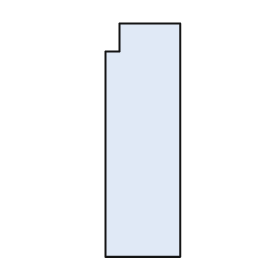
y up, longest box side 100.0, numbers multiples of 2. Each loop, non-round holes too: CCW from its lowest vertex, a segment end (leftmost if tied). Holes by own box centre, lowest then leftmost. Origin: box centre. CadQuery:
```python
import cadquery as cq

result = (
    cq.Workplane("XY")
    .moveTo(-16.0, -50.0)
    .lineTo(16.0, -50.0)
    .lineTo(16.0, 50.0)
    .lineTo(-10.0, 50.0)
    .lineTo(-10.0, 38.0)
    .lineTo(-16.0, 38.0)
    .close()
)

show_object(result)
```